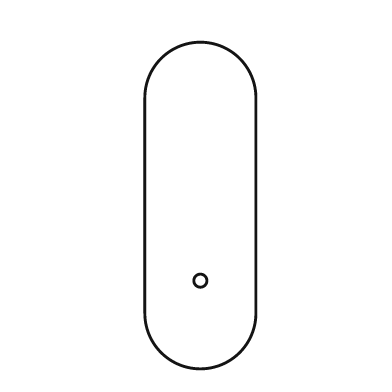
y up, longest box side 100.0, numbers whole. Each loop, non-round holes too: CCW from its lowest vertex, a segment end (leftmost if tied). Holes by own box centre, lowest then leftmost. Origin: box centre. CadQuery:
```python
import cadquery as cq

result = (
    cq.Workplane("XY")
    .moveTo(-17.0, -33.0)
    .threePointArc((0.0, -50.0), (17.0, -33.0))
    .lineTo(17.0, 33.0)
    .threePointArc((0.0, 50.0), (-17.0, 33.0))
    .close()
    .moveTo(0.0, -23.0)
    .circle(2.0)
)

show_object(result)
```